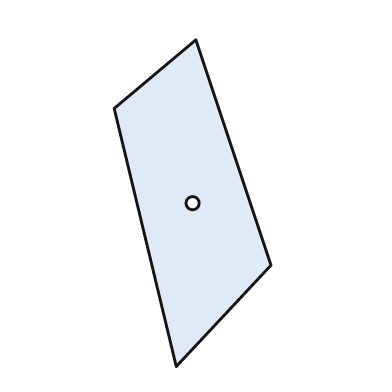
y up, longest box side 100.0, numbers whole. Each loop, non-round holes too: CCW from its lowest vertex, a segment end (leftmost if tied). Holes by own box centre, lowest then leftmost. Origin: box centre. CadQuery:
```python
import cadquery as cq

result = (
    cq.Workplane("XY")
    .moveTo(-5.0, -50.0)
    .lineTo(24.0, -19.0)
    .lineTo(1.0, 50.0)
    .lineTo(-24.0, 29.0)
    .close()
    .moveTo(0.0, 0.0)
    .circle(2.0)
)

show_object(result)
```